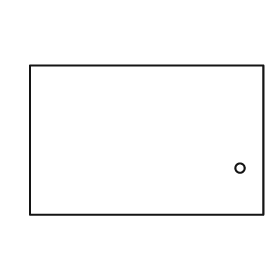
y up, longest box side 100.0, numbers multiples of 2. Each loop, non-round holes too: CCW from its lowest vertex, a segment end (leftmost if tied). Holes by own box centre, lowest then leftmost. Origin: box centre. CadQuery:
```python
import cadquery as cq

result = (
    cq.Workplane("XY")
    .moveTo(-50.0, -32.0)
    .lineTo(50.0, -32.0)
    .lineTo(50.0, 32.0)
    .lineTo(-50.0, 32.0)
    .close()
    .moveTo(40.0, -12.0)
    .circle(2.0)
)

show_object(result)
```